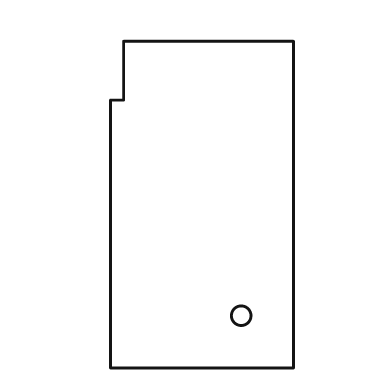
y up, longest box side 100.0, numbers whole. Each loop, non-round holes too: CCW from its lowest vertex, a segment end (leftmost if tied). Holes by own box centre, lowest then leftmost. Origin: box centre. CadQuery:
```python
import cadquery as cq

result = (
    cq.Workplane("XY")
    .moveTo(-28.0, -50.0)
    .lineTo(28.0, -50.0)
    .lineTo(28.0, 50.0)
    .lineTo(-24.0, 50.0)
    .lineTo(-24.0, 32.0)
    .lineTo(-28.0, 32.0)
    .close()
    .moveTo(12.0, -34.0)
    .circle(3.0)
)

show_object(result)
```